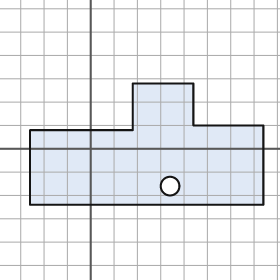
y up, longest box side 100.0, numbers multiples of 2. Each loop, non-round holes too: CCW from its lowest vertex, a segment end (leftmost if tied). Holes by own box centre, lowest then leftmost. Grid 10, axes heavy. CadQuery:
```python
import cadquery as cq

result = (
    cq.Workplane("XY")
    .moveTo(-26.0, -24.0)
    .lineTo(74.0, -24.0)
    .lineTo(74.0, 10.0)
    .lineTo(44.0, 10.0)
    .lineTo(44.0, 28.0)
    .lineTo(18.0, 28.0)
    .lineTo(18.0, 8.0)
    .lineTo(-26.0, 8.0)
    .close()
    .moveTo(34.0, -16.0)
    .circle(4.0)
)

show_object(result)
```